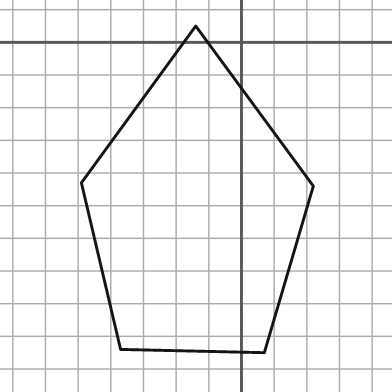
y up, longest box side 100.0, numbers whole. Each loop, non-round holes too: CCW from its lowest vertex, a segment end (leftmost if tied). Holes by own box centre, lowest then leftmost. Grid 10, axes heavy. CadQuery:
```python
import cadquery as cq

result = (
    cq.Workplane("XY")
    .moveTo(7.0, -95.0)
    .lineTo(22.0, -44.0)
    .lineTo(-14.0, 5.0)
    .lineTo(-49.0, -43.0)
    .lineTo(-37.0, -94.0)
    .close()
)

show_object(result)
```